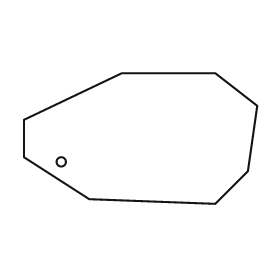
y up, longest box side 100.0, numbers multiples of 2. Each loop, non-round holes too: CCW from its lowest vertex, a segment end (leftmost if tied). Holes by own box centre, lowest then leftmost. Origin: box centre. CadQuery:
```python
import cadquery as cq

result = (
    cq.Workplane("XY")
    .moveTo(32.0, -28.0)
    .lineTo(46.0, -14.0)
    .lineTo(50.0, 14.0)
    .lineTo(32.0, 28.0)
    .lineTo(-8.0, 28.0)
    .lineTo(-50.0, 8.0)
    .lineTo(-50.0, -8.0)
    .lineTo(-22.0, -26.0)
    .close()
    .moveTo(-34.0, -10.0)
    .circle(2.0)
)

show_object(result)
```